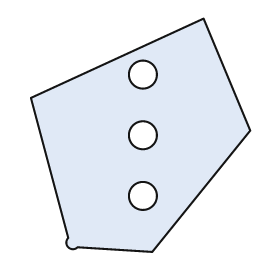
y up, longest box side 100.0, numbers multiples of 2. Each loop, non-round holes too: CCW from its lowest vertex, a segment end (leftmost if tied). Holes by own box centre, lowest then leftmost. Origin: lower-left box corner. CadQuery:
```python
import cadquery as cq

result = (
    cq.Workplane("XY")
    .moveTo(52.0, 0.0)
    .lineTo(94.0, 52.0)
    .lineTo(74.0, 100.0)
    .lineTo(0.0, 66.0)
    .lineTo(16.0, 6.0)
    .threePointArc((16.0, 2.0), (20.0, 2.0))
    .close()
    .moveTo(48.0, 24.0)
    .circle(6.0)
    .moveTo(48.0, 50.0)
    .circle(6.0)
    .moveTo(48.0, 76.0)
    .circle(6.0)
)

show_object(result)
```